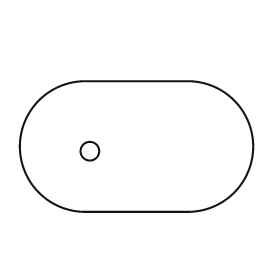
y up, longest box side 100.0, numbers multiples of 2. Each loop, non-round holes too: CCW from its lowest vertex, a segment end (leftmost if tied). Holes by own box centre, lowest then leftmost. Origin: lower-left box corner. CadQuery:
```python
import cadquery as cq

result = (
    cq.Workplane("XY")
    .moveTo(28.0, 0.0)
    .lineTo(72.0, 0.0)
    .threePointArc((100.0, 28.0), (72.0, 56.0))
    .lineTo(28.0, 56.0)
    .threePointArc((0.0, 28.0), (28.0, 0.0))
    .close()
    .moveTo(30.0, 26.0)
    .circle(4.0)
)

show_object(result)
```